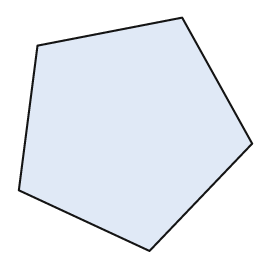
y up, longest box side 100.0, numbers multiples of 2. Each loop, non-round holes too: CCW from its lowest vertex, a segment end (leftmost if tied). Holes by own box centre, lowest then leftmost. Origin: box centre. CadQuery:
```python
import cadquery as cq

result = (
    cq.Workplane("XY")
    .moveTo(6.0, -50.0)
    .lineTo(50.0, -4.0)
    .lineTo(20.0, 50.0)
    .lineTo(-42.0, 38.0)
    .lineTo(-50.0, -24.0)
    .close()
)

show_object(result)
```